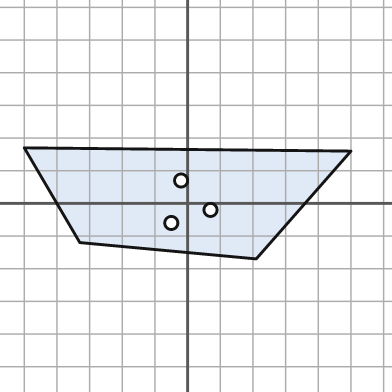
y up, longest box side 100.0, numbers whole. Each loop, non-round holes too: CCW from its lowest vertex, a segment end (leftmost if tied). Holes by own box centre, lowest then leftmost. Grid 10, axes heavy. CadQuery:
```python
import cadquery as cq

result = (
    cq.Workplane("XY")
    .moveTo(21.0, -17.0)
    .lineTo(50.0, 16.0)
    .lineTo(-50.0, 17.0)
    .lineTo(-33.0, -12.0)
    .close()
    .moveTo(-5.0, -6.0)
    .circle(2.0)
    .moveTo(7.0, -2.0)
    .circle(2.0)
    .moveTo(-2.0, 7.0)
    .circle(2.0)
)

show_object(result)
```